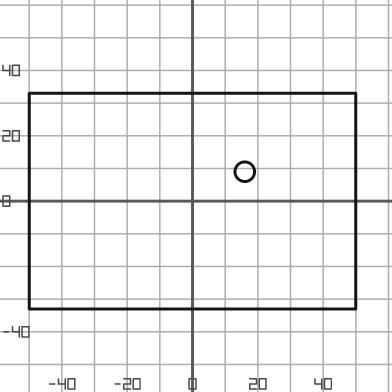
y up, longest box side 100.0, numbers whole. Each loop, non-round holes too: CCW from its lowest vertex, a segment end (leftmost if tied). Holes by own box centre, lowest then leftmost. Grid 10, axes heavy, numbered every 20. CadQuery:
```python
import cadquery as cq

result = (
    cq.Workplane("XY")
    .moveTo(-50.0, -33.0)
    .lineTo(50.0, -33.0)
    .lineTo(50.0, 33.0)
    .lineTo(-50.0, 33.0)
    .close()
    .moveTo(16.0, 9.0)
    .circle(3.0)
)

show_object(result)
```